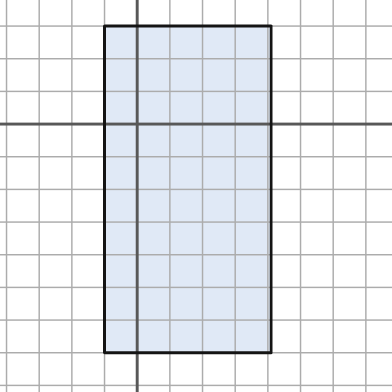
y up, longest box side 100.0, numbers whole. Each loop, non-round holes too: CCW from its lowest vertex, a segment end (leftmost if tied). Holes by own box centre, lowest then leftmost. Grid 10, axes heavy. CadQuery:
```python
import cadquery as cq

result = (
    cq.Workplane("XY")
    .moveTo(-10.0, -70.0)
    .lineTo(41.0, -70.0)
    .lineTo(41.0, 30.0)
    .lineTo(-10.0, 30.0)
    .close()
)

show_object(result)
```